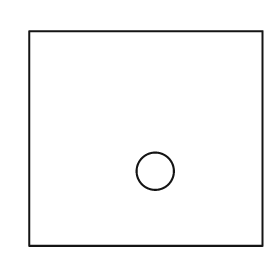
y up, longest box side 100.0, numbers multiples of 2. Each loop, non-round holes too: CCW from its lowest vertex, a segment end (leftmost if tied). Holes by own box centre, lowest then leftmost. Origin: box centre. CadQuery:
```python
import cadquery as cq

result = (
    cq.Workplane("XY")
    .moveTo(-50.0, -46.0)
    .lineTo(50.0, -46.0)
    .lineTo(50.0, 46.0)
    .lineTo(-50.0, 46.0)
    .close()
    .moveTo(4.0, -14.0)
    .circle(8.0)
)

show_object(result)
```